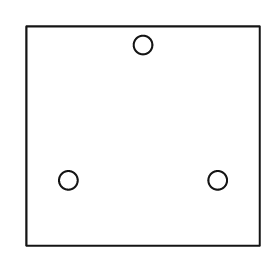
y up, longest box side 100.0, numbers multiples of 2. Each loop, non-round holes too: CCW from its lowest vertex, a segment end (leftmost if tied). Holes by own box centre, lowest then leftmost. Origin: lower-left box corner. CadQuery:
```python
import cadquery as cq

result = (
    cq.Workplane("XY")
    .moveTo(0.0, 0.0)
    .lineTo(100.0, 0.0)
    .lineTo(100.0, 94.0)
    .lineTo(0.0, 94.0)
    .close()
    .moveTo(18.0, 28.0)
    .circle(4.0)
    .moveTo(82.0, 28.0)
    .circle(4.0)
    .moveTo(50.0, 86.0)
    .circle(4.0)
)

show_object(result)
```